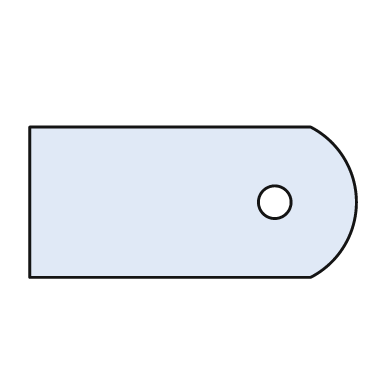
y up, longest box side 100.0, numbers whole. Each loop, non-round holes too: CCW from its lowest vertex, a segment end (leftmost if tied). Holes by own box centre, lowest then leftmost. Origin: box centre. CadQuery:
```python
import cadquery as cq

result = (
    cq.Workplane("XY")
    .moveTo(-50.0, -23.0)
    .lineTo(36.0, -23.0)
    .threePointArc((50.0, 0.0), (36.0, 23.0))
    .lineTo(-50.0, 23.0)
    .close()
    .moveTo(25.0, 0.0)
    .circle(5.0)
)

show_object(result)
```